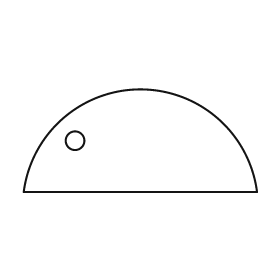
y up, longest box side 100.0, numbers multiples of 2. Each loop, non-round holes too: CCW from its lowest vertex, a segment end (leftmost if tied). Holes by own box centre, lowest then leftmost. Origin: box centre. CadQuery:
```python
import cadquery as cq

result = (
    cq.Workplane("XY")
    .moveTo(-50.0, -22.0)
    .lineTo(50.0, -22.0)
    .threePointArc((0.0, 22.0), (-50.0, -22.0))
    .close()
    .moveTo(-28.0, 0.0)
    .circle(4.0)
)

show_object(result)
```